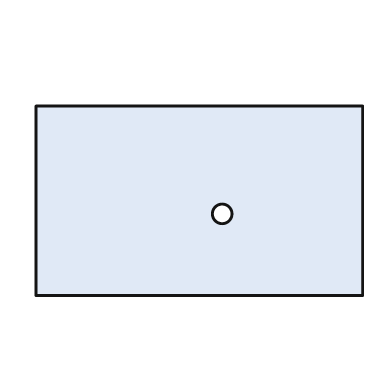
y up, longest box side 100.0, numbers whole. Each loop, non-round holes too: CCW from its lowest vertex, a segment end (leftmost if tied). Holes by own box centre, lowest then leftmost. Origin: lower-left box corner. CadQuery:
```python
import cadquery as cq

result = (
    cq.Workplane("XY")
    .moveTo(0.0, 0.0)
    .lineTo(100.0, 0.0)
    .lineTo(100.0, 58.0)
    .lineTo(0.0, 58.0)
    .close()
    .moveTo(57.0, 25.0)
    .circle(3.0)
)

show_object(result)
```